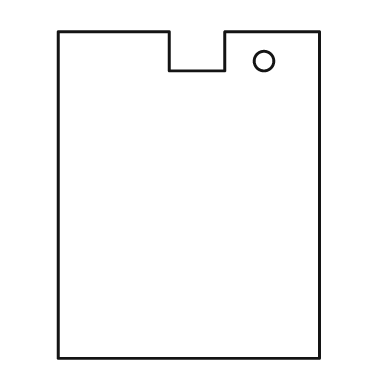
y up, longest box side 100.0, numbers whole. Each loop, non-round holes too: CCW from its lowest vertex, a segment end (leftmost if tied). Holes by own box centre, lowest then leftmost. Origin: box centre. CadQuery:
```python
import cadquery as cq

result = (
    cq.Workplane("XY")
    .moveTo(-40.0, -50.0)
    .lineTo(40.0, -50.0)
    .lineTo(40.0, 50.0)
    .lineTo(11.0, 50.0)
    .lineTo(11.0, 38.0)
    .lineTo(-6.0, 38.0)
    .lineTo(-6.0, 50.0)
    .lineTo(-40.0, 50.0)
    .close()
    .moveTo(23.0, 41.0)
    .circle(3.0)
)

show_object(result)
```